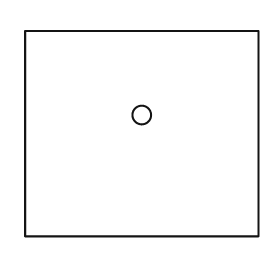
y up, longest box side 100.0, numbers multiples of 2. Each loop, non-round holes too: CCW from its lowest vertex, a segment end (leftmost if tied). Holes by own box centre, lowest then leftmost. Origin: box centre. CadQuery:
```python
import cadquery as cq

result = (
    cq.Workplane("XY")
    .moveTo(-50.0, -44.0)
    .lineTo(50.0, -44.0)
    .lineTo(50.0, 44.0)
    .lineTo(-50.0, 44.0)
    .close()
    .moveTo(0.0, 8.0)
    .circle(4.0)
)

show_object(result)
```